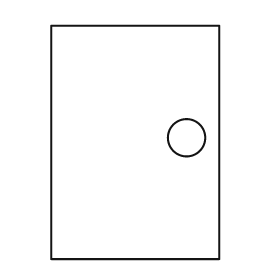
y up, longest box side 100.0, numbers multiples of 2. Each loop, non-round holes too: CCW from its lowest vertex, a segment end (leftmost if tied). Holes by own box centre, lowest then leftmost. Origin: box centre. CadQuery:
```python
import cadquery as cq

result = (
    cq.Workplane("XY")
    .moveTo(-36.0, -50.0)
    .lineTo(36.0, -50.0)
    .lineTo(36.0, 50.0)
    .lineTo(-36.0, 50.0)
    .close()
    .moveTo(22.0, 2.0)
    .circle(8.0)
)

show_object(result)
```